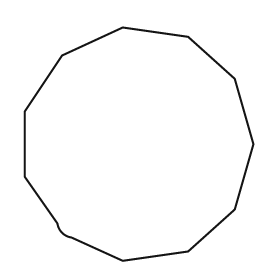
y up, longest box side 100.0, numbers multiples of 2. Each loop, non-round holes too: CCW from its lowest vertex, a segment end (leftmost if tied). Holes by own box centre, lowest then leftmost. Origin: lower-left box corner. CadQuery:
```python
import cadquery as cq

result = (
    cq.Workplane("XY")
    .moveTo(42.0, 0.0)
    .lineTo(70.0, 4.0)
    .lineTo(90.0, 22.0)
    .lineTo(98.0, 50.0)
    .lineTo(90.0, 78.0)
    .lineTo(70.0, 96.0)
    .lineTo(42.0, 100.0)
    .lineTo(16.0, 88.0)
    .lineTo(0.0, 64.0)
    .lineTo(0.0, 36.0)
    .lineTo(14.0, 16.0)
    .threePointArc((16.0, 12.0), (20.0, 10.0))
    .close()
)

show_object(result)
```